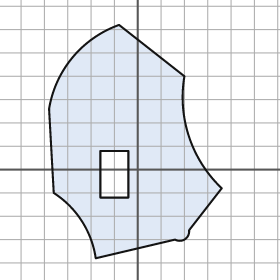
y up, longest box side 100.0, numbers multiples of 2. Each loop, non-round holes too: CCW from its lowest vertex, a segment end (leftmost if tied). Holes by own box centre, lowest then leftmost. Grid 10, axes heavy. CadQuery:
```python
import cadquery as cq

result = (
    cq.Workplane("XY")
    .moveTo(-18.0, -38.0)
    .lineTo(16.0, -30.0)
    .threePointArc((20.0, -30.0), (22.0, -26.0))
    .lineTo(36.0, -8.0)
    .threePointArc((22.0, 14.0), (20.0, 40.0))
    .lineTo(-8.0, 62.0)
    .threePointArc((-28.0, 48.0), (-38.0, 26.0))
    .lineTo(-36.0, -10.0)
    .threePointArc((-24.0, -22.0), (-18.0, -38.0))
    .close()
    .moveTo(-16.0, -12.0)
    .lineTo(-4.0, -12.0)
    .lineTo(-4.0, 8.0)
    .lineTo(-16.0, 8.0)
    .close()
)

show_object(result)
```